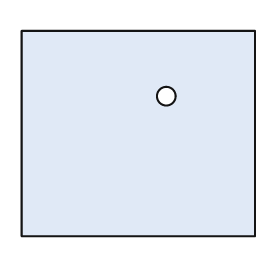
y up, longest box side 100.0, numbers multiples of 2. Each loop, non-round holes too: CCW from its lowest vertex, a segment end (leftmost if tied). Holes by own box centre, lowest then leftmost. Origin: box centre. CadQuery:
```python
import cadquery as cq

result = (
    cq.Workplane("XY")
    .moveTo(-50.0, -44.0)
    .lineTo(50.0, -44.0)
    .lineTo(50.0, 44.0)
    .lineTo(-50.0, 44.0)
    .close()
    .moveTo(12.0, 16.0)
    .circle(4.0)
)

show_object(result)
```